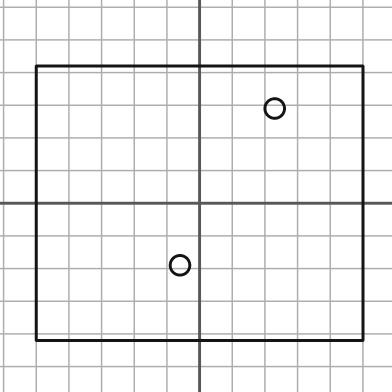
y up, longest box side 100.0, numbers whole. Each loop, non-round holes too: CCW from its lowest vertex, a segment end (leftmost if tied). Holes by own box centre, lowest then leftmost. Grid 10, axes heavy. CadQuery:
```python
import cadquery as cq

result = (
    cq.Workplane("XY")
    .moveTo(-50.0, -42.0)
    .lineTo(50.0, -42.0)
    .lineTo(50.0, 42.0)
    .lineTo(-50.0, 42.0)
    .close()
    .moveTo(-6.0, -19.0)
    .circle(3.0)
    .moveTo(23.0, 29.0)
    .circle(3.0)
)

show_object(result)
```